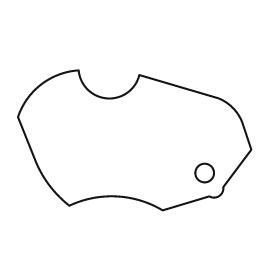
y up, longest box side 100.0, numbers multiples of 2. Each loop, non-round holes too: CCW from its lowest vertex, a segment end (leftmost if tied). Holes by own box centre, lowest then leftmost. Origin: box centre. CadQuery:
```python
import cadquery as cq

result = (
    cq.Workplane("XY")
    .moveTo(12.0, -30.0)
    .lineTo(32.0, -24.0)
    .threePointArc((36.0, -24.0), (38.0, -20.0))
    .lineTo(50.0, -4.0)
    .lineTo(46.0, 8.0)
    .threePointArc((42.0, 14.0), (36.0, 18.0))
    .lineTo(2.0, 28.0)
    .threePointArc((-12.0, 18.0), (-24.0, 30.0))
    .threePointArc((-40.0, 24.0), (-50.0, 10.0))
    .lineTo(-42.0, -10.0)
    .threePointArc((-36.0, -20.0), (-28.0, -28.0))
    .threePointArc((-8.0, -24.0), (12.0, -30.0))
    .close()
    .moveTo(30.0, -14.0)
    .circle(4.0)
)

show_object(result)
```